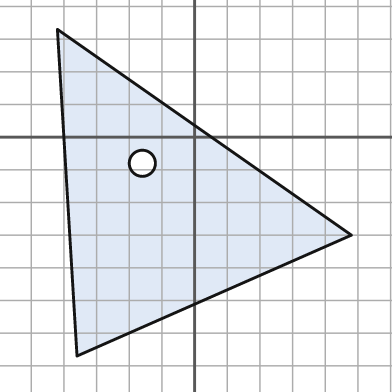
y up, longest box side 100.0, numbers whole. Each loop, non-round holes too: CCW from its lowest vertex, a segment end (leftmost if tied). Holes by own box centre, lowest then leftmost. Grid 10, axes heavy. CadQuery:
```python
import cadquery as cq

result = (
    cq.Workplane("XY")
    .moveTo(-36.0, -67.0)
    .lineTo(48.0, -30.0)
    .lineTo(-42.0, 33.0)
    .close()
    .moveTo(-16.0, -8.0)
    .circle(4.0)
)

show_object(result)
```